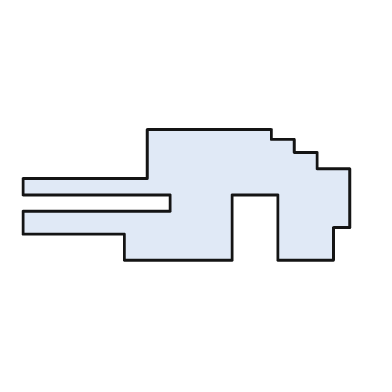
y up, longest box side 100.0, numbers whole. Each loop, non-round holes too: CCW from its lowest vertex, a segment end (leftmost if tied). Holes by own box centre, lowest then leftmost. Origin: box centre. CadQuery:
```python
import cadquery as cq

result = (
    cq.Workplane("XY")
    .moveTo(-19.0, -20.0)
    .lineTo(14.0, -20.0)
    .lineTo(14.0, 0.0)
    .lineTo(28.0, 0.0)
    .lineTo(28.0, -20.0)
    .lineTo(45.0, -20.0)
    .lineTo(45.0, -10.0)
    .lineTo(50.0, -10.0)
    .lineTo(50.0, 8.0)
    .lineTo(40.0, 8.0)
    .lineTo(40.0, 13.0)
    .lineTo(33.0, 13.0)
    .lineTo(33.0, 17.0)
    .lineTo(26.0, 17.0)
    .lineTo(26.0, 20.0)
    .lineTo(-12.0, 20.0)
    .lineTo(-12.0, 5.0)
    .lineTo(-50.0, 5.0)
    .lineTo(-50.0, 0.0)
    .lineTo(-5.0, 0.0)
    .lineTo(-5.0, -5.0)
    .lineTo(-50.0, -5.0)
    .lineTo(-50.0, -12.0)
    .lineTo(-19.0, -12.0)
    .close()
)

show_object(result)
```